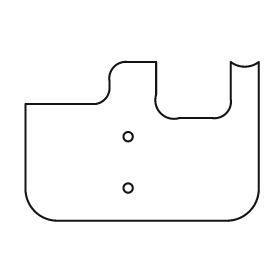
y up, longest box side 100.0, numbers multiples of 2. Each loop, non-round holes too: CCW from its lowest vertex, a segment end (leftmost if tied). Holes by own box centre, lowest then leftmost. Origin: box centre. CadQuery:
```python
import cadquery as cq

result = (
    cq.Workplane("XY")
    .moveTo(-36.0, -34.0)
    .lineTo(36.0, -34.0)
    .threePointArc((46.0, -30.0), (50.0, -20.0))
    .lineTo(50.0, 34.0)
    .threePointArc((44.0, 32.0), (38.0, 34.0))
    .lineTo(38.0, 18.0)
    .threePointArc((36.0, 12.0), (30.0, 10.0))
    .lineTo(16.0, 10.0)
    .threePointArc((8.0, 12.0), (6.0, 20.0))
    .lineTo(6.0, 34.0)
    .lineTo(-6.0, 34.0)
    .threePointArc((-12.0, 32.0), (-14.0, 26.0))
    .lineTo(-14.0, 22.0)
    .threePointArc((-16.0, 18.0), (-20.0, 16.0))
    .lineTo(-50.0, 16.0)
    .lineTo(-50.0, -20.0)
    .threePointArc((-46.0, -30.0), (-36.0, -34.0))
    .close()
    .moveTo(-6.0, -20.0)
    .circle(2.0)
    .moveTo(-6.0, 2.0)
    .circle(2.0)
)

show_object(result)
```